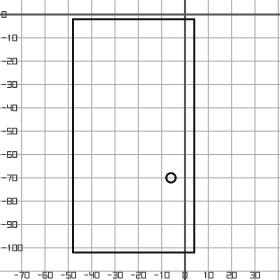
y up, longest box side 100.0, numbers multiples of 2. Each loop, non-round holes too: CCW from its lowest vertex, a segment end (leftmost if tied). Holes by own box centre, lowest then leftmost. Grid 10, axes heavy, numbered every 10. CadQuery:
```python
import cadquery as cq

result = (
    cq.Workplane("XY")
    .moveTo(-48.0, -102.0)
    .lineTo(4.0, -102.0)
    .lineTo(4.0, -2.0)
    .lineTo(-48.0, -2.0)
    .close()
    .moveTo(-6.0, -70.0)
    .circle(2.0)
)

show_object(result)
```